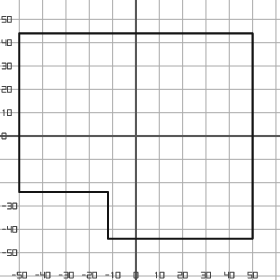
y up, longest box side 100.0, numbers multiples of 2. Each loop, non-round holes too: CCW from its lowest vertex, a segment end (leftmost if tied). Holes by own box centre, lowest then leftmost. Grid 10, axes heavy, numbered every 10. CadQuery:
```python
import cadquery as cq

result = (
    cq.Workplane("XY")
    .moveTo(-12.0, -44.0)
    .lineTo(50.0, -44.0)
    .lineTo(50.0, 44.0)
    .lineTo(-50.0, 44.0)
    .lineTo(-50.0, -24.0)
    .lineTo(-12.0, -24.0)
    .close()
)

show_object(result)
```